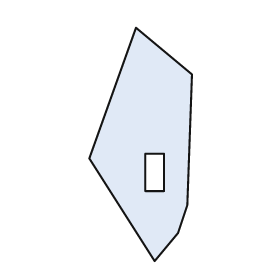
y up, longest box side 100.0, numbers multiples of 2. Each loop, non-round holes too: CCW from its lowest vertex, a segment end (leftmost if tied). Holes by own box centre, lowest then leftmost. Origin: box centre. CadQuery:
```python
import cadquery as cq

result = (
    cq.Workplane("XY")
    .moveTo(6.0, -50.0)
    .lineTo(16.0, -38.0)
    .lineTo(20.0, -26.0)
    .lineTo(22.0, 30.0)
    .lineTo(-2.0, 50.0)
    .lineTo(-22.0, -6.0)
    .close()
    .moveTo(2.0, -20.0)
    .lineTo(10.0, -20.0)
    .lineTo(10.0, -4.0)
    .lineTo(2.0, -4.0)
    .close()
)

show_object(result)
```